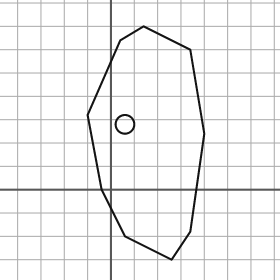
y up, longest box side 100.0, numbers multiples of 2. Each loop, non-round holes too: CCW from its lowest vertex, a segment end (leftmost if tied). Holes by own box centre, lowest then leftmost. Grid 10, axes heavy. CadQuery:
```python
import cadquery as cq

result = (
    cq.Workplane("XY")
    .moveTo(26.0, -30.0)
    .lineTo(34.0, -18.0)
    .lineTo(40.0, 24.0)
    .lineTo(34.0, 60.0)
    .lineTo(14.0, 70.0)
    .lineTo(4.0, 64.0)
    .lineTo(-10.0, 32.0)
    .lineTo(-4.0, 0.0)
    .lineTo(6.0, -20.0)
    .close()
    .moveTo(6.0, 28.0)
    .circle(4.0)
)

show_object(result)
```